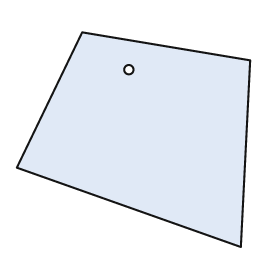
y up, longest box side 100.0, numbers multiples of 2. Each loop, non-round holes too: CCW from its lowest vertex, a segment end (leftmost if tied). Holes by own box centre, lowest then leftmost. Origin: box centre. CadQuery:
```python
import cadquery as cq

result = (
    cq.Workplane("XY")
    .moveTo(46.0, -46.0)
    .lineTo(50.0, 34.0)
    .lineTo(-22.0, 46.0)
    .lineTo(-50.0, -12.0)
    .close()
    .moveTo(-2.0, 30.0)
    .circle(2.0)
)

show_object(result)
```